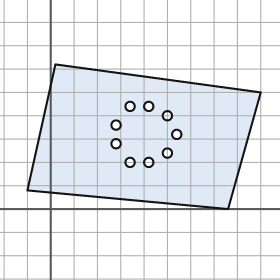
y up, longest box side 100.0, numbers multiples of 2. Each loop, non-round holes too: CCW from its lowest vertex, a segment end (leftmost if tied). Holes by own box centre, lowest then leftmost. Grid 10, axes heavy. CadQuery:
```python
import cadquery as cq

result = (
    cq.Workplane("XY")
    .moveTo(76.0, 0.0)
    .lineTo(90.0, 50.0)
    .lineTo(2.0, 62.0)
    .lineTo(-10.0, 8.0)
    .close()
    .moveTo(34.0, 20.0)
    .circle(2.0)
    .moveTo(42.0, 20.0)
    .circle(2.0)
    .moveTo(50.0, 24.0)
    .circle(2.0)
    .moveTo(28.0, 28.0)
    .circle(2.0)
    .moveTo(54.0, 32.0)
    .circle(2.0)
    .moveTo(28.0, 36.0)
    .circle(2.0)
    .moveTo(50.0, 40.0)
    .circle(2.0)
    .moveTo(34.0, 44.0)
    .circle(2.0)
    .moveTo(42.0, 44.0)
    .circle(2.0)
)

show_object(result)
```